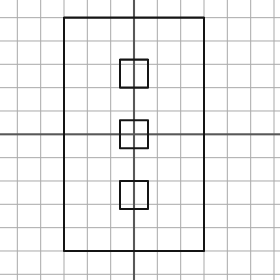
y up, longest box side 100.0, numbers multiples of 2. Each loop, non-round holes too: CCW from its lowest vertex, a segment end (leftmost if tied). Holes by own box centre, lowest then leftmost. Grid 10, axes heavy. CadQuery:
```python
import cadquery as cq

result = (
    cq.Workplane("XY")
    .moveTo(-30.0, -50.0)
    .lineTo(30.0, -50.0)
    .lineTo(30.0, 50.0)
    .lineTo(-30.0, 50.0)
    .close()
    .moveTo(-6.0, -32.0)
    .lineTo(6.0, -32.0)
    .lineTo(6.0, -20.0)
    .lineTo(-6.0, -20.0)
    .close()
    .moveTo(-6.0, -6.0)
    .lineTo(6.0, -6.0)
    .lineTo(6.0, 6.0)
    .lineTo(-6.0, 6.0)
    .close()
    .moveTo(-6.0, 20.0)
    .lineTo(6.0, 20.0)
    .lineTo(6.0, 32.0)
    .lineTo(-6.0, 32.0)
    .close()
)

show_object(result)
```